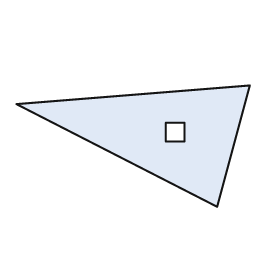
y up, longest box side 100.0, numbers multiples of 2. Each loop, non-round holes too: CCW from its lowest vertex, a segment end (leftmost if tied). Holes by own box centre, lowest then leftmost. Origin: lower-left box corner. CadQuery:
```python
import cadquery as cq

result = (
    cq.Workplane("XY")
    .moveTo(86.0, 0.0)
    .lineTo(100.0, 52.0)
    .lineTo(0.0, 44.0)
    .close()
    .moveTo(64.0, 28.0)
    .lineTo(72.0, 28.0)
    .lineTo(72.0, 36.0)
    .lineTo(64.0, 36.0)
    .close()
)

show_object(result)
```